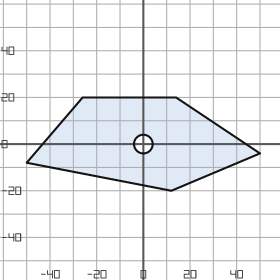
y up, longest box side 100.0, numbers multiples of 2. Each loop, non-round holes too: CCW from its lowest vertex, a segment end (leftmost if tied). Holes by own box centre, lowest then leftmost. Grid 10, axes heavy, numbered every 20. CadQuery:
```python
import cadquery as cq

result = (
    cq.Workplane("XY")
    .moveTo(12.0, -20.0)
    .lineTo(50.0, -4.0)
    .lineTo(14.0, 20.0)
    .lineTo(-26.0, 20.0)
    .lineTo(-50.0, -8.0)
    .close()
    .moveTo(0.0, 0.0)
    .circle(4.0)
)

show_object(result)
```